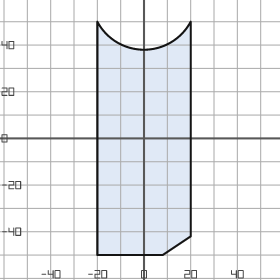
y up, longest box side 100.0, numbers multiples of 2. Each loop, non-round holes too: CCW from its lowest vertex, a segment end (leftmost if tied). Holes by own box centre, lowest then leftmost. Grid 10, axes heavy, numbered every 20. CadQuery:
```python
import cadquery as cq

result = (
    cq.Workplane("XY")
    .moveTo(-20.0, -50.0)
    .lineTo(8.0, -50.0)
    .lineTo(20.0, -42.0)
    .lineTo(20.0, 50.0)
    .threePointArc((0.0, 38.0), (-20.0, 50.0))
    .close()
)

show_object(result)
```